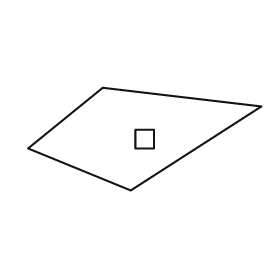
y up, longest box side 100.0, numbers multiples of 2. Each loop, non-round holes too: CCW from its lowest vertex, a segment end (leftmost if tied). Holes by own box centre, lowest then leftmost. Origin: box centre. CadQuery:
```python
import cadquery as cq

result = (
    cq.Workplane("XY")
    .moveTo(-6.0, -22.0)
    .lineTo(50.0, 14.0)
    .lineTo(-18.0, 22.0)
    .lineTo(-50.0, -4.0)
    .close()
    .moveTo(-4.0, -4.0)
    .lineTo(4.0, -4.0)
    .lineTo(4.0, 4.0)
    .lineTo(-4.0, 4.0)
    .close()
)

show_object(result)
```